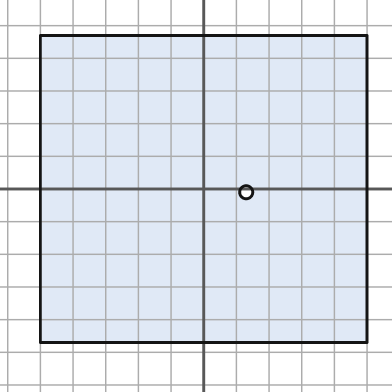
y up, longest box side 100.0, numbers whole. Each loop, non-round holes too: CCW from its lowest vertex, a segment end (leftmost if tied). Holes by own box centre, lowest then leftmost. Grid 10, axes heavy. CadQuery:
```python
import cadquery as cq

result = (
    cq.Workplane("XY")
    .moveTo(-50.0, -47.0)
    .lineTo(50.0, -47.0)
    .lineTo(50.0, 47.0)
    .lineTo(-50.0, 47.0)
    .close()
    .moveTo(13.0, -1.0)
    .circle(2.0)
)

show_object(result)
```